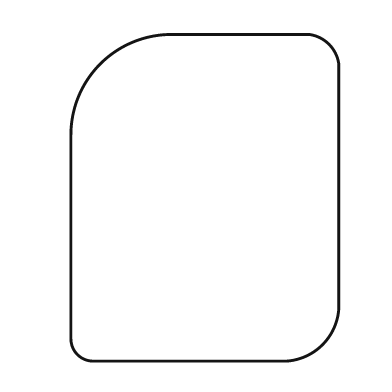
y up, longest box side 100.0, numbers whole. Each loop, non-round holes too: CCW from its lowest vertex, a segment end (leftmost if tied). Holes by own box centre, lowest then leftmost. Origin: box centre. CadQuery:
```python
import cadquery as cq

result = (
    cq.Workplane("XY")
    .moveTo(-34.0, -50.0)
    .lineTo(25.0, -50.0)
    .threePointArc((36.0, -45.0), (41.0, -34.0))
    .lineTo(41.0, 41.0)
    .threePointArc((38.0, 47.0), (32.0, 50.0))
    .lineTo(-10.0, 50.0)
    .threePointArc((-32.0, 41.0), (-41.0, 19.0))
    .lineTo(-41.0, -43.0)
    .threePointArc((-39.0, -48.0), (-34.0, -50.0))
    .close()
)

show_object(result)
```